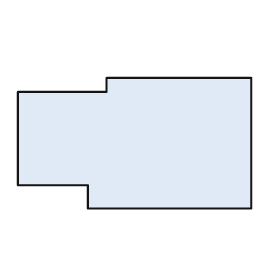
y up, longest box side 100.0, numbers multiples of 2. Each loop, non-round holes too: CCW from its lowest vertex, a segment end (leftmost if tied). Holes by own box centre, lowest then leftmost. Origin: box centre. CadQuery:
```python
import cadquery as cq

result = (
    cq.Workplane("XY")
    .moveTo(-20.0, -28.0)
    .lineTo(50.0, -28.0)
    .lineTo(50.0, 28.0)
    .lineTo(-12.0, 28.0)
    .lineTo(-12.0, 22.0)
    .lineTo(-50.0, 22.0)
    .lineTo(-50.0, -18.0)
    .lineTo(-20.0, -18.0)
    .close()
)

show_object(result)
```